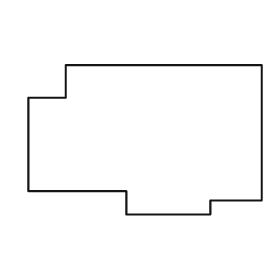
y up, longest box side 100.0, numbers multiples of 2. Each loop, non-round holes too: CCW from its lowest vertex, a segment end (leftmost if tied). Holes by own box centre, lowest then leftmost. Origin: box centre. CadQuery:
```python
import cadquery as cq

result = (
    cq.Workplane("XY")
    .moveTo(-8.0, -32.0)
    .lineTo(28.0, -32.0)
    .lineTo(28.0, -26.0)
    .lineTo(50.0, -26.0)
    .lineTo(50.0, 32.0)
    .lineTo(-34.0, 32.0)
    .lineTo(-34.0, 18.0)
    .lineTo(-50.0, 18.0)
    .lineTo(-50.0, -22.0)
    .lineTo(-8.0, -22.0)
    .close()
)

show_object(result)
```